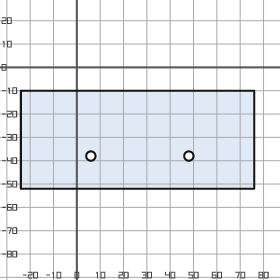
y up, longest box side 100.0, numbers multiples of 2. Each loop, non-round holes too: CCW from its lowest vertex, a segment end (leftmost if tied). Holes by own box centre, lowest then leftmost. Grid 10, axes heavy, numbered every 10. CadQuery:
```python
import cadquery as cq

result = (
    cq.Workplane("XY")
    .moveTo(-24.0, -52.0)
    .lineTo(76.0, -52.0)
    .lineTo(76.0, -10.0)
    .lineTo(-24.0, -10.0)
    .close()
    .moveTo(6.0, -38.0)
    .circle(2.0)
    .moveTo(48.0, -38.0)
    .circle(2.0)
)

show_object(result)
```